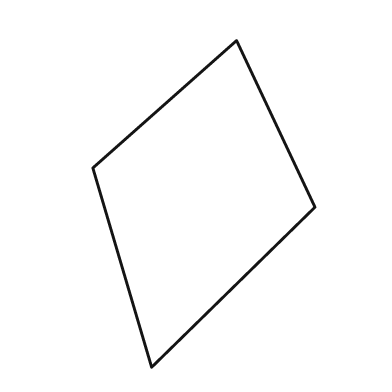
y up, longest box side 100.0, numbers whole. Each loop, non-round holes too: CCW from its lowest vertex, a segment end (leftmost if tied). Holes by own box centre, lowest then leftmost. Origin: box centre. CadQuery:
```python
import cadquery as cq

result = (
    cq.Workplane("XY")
    .moveTo(-16.0, -50.0)
    .lineTo(34.0, -1.0)
    .lineTo(10.0, 50.0)
    .lineTo(-34.0, 11.0)
    .close()
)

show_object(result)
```